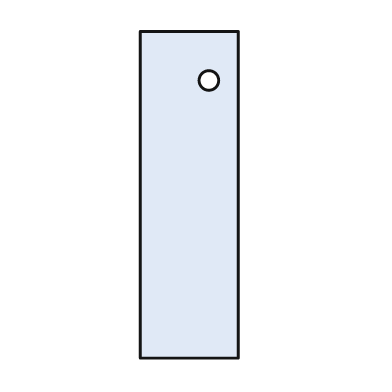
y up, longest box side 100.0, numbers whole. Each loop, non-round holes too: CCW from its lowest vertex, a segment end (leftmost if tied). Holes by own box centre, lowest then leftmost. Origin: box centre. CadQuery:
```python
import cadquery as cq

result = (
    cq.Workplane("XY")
    .moveTo(-15.0, -50.0)
    .lineTo(15.0, -50.0)
    .lineTo(15.0, 50.0)
    .lineTo(-15.0, 50.0)
    .close()
    .moveTo(6.0, 35.0)
    .circle(3.0)
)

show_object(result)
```